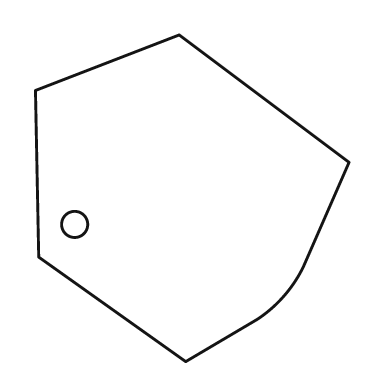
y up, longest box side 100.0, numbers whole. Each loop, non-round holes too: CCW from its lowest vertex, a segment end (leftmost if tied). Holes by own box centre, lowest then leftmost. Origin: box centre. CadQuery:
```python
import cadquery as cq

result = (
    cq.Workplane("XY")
    .moveTo(-2.0, -50.0)
    .lineTo(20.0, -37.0)
    .threePointArc((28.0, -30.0), (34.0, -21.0))
    .lineTo(48.0, 11.0)
    .lineTo(-4.0, 50.0)
    .lineTo(-48.0, 33.0)
    .lineTo(-47.0, -18.0)
    .close()
    .moveTo(-36.0, -8.0)
    .circle(4.0)
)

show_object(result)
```